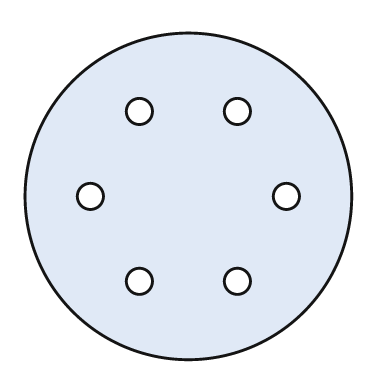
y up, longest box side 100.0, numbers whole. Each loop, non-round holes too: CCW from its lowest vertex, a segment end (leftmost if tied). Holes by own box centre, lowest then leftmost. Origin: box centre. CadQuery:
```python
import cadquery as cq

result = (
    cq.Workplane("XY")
    .moveTo(0.0, 0.0)
    .circle(50.0)
    .moveTo(-15.0, -26.0)
    .circle(4.0)
    .moveTo(15.0, -26.0)
    .circle(4.0)
    .moveTo(-30.0, 0.0)
    .circle(4.0)
    .moveTo(30.0, 0.0)
    .circle(4.0)
    .moveTo(-15.0, 26.0)
    .circle(4.0)
    .moveTo(15.0, 26.0)
    .circle(4.0)
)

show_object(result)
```